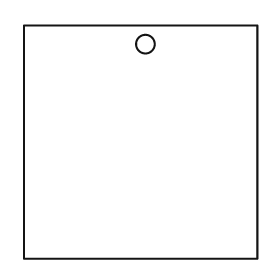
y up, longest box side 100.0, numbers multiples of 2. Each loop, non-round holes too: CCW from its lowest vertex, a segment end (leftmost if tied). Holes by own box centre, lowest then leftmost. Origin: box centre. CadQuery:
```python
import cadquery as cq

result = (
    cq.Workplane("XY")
    .moveTo(-50.0, -50.0)
    .lineTo(50.0, -50.0)
    .lineTo(50.0, 50.0)
    .lineTo(-50.0, 50.0)
    .close()
    .moveTo(2.0, 42.0)
    .circle(4.0)
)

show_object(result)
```